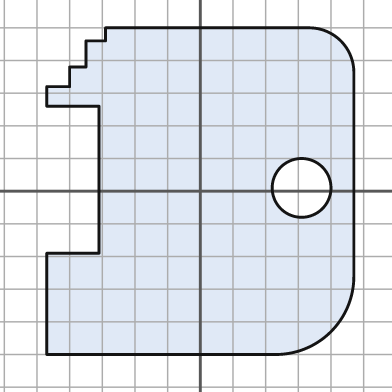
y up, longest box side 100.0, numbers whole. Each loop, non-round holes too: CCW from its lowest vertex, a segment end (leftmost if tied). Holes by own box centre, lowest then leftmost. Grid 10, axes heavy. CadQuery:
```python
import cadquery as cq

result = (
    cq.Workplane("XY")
    .moveTo(-47.0, -50.0)
    .lineTo(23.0, -50.0)
    .threePointArc((40.0, -43.0), (47.0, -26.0))
    .lineTo(47.0, 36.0)
    .threePointArc((43.0, 46.0), (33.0, 50.0))
    .lineTo(-29.0, 50.0)
    .lineTo(-29.0, 46.0)
    .lineTo(-35.0, 46.0)
    .lineTo(-35.0, 38.0)
    .lineTo(-40.0, 38.0)
    .lineTo(-40.0, 32.0)
    .lineTo(-47.0, 32.0)
    .lineTo(-47.0, 26.0)
    .lineTo(-31.0, 26.0)
    .lineTo(-31.0, -19.0)
    .lineTo(-47.0, -19.0)
    .close()
    .moveTo(31.0, 1.0)
    .circle(9.0)
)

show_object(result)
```